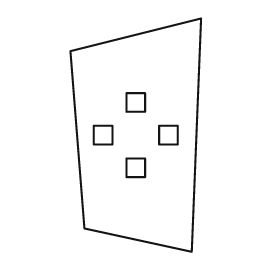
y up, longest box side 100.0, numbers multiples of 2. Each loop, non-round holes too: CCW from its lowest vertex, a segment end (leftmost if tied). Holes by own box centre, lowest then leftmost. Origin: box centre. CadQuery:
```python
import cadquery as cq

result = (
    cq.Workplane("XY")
    .moveTo(24.0, -50.0)
    .lineTo(28.0, 50.0)
    .lineTo(-28.0, 36.0)
    .lineTo(-22.0, -40.0)
    .close()
    .moveTo(-4.0, -18.0)
    .lineTo(4.0, -18.0)
    .lineTo(4.0, -10.0)
    .lineTo(-4.0, -10.0)
    .close()
    .moveTo(-18.0, -4.0)
    .lineTo(-10.0, -4.0)
    .lineTo(-10.0, 4.0)
    .lineTo(-18.0, 4.0)
    .close()
    .moveTo(10.0, -4.0)
    .lineTo(18.0, -4.0)
    .lineTo(18.0, 4.0)
    .lineTo(10.0, 4.0)
    .close()
    .moveTo(-4.0, 10.0)
    .lineTo(4.0, 10.0)
    .lineTo(4.0, 18.0)
    .lineTo(-4.0, 18.0)
    .close()
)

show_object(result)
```